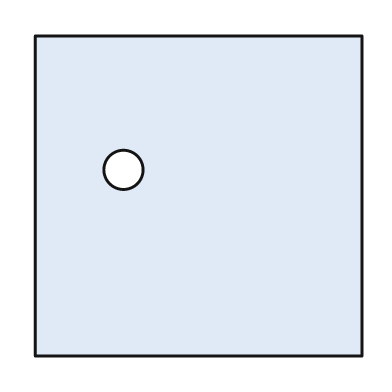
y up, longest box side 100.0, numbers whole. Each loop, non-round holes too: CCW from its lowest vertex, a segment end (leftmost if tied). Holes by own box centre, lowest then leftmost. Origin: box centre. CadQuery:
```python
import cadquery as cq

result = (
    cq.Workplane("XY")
    .moveTo(-50.0, -49.0)
    .lineTo(50.0, -49.0)
    .lineTo(50.0, 49.0)
    .lineTo(-50.0, 49.0)
    .close()
    .moveTo(-23.0, 8.0)
    .circle(6.0)
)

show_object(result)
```